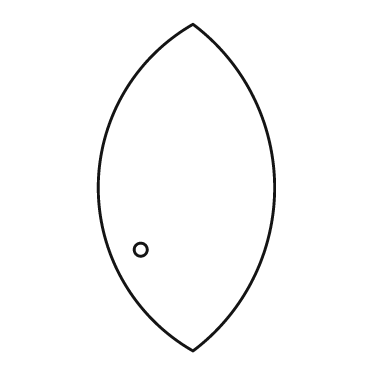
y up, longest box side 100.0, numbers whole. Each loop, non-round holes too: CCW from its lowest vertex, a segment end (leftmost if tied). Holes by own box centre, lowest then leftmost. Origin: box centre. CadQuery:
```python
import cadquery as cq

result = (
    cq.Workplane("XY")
    .moveTo(2.0, -50.0)
    .threePointArc((27.0, 0.0), (2.0, 50.0))
    .threePointArc((-27.0, 0.0), (2.0, -50.0))
    .close()
    .moveTo(-14.0, -19.0)
    .circle(2.0)
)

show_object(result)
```